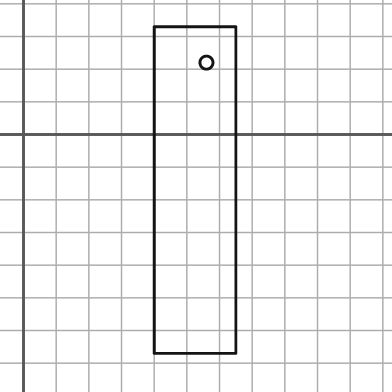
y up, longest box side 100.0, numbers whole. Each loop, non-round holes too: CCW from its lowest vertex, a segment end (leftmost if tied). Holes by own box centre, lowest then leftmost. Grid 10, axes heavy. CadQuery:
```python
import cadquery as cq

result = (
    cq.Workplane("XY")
    .moveTo(40.0, -67.0)
    .lineTo(65.0, -67.0)
    .lineTo(65.0, 33.0)
    .lineTo(40.0, 33.0)
    .close()
    .moveTo(56.0, 22.0)
    .circle(2.0)
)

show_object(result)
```